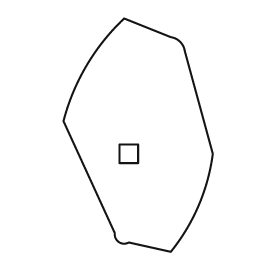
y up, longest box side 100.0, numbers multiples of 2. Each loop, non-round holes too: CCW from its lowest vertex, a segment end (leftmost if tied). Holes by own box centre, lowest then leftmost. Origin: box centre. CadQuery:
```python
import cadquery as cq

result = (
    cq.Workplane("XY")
    .moveTo(14.0, -50.0)
    .threePointArc((26.0, -30.0), (32.0, -8.0))
    .lineTo(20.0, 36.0)
    .threePointArc((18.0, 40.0), (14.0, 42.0))
    .lineTo(-6.0, 50.0)
    .threePointArc((-22.0, 30.0), (-32.0, 6.0))
    .lineTo(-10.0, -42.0)
    .threePointArc((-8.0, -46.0), (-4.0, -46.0))
    .close()
    .moveTo(-8.0, -12.0)
    .lineTo(0.0, -12.0)
    .lineTo(0.0, -4.0)
    .lineTo(-8.0, -4.0)
    .close()
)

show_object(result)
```